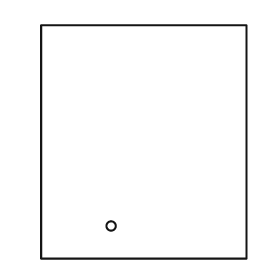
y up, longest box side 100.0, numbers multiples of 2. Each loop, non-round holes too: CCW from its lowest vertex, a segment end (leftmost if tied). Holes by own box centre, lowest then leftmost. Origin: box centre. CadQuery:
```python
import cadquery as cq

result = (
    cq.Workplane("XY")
    .moveTo(-44.0, -50.0)
    .lineTo(44.0, -50.0)
    .lineTo(44.0, 50.0)
    .lineTo(-44.0, 50.0)
    .close()
    .moveTo(-14.0, -36.0)
    .circle(2.0)
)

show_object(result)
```